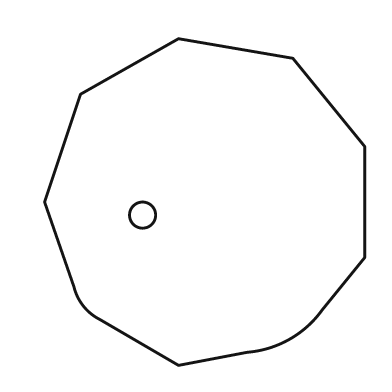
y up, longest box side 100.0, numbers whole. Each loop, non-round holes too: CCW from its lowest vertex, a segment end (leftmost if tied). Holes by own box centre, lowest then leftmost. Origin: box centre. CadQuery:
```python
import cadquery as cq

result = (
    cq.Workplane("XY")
    .moveTo(-8.0, -50.0)
    .lineTo(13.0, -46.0)
    .threePointArc((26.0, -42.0), (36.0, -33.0))
    .lineTo(49.0, -17.0)
    .lineTo(49.0, 17.0)
    .lineTo(27.0, 44.0)
    .lineTo(-8.0, 50.0)
    .lineTo(-38.0, 33.0)
    .lineTo(-49.0, 0.0)
    .lineTo(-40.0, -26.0)
    .threePointArc((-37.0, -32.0), (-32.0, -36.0))
    .close()
    .moveTo(-19.0, -4.0)
    .circle(4.0)
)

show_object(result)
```